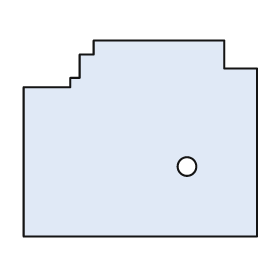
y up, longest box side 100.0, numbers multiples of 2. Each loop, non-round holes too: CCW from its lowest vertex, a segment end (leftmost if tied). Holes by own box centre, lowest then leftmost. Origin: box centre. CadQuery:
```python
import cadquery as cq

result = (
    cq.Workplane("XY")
    .moveTo(-50.0, -42.0)
    .lineTo(50.0, -42.0)
    .lineTo(50.0, 30.0)
    .lineTo(36.0, 30.0)
    .lineTo(36.0, 42.0)
    .lineTo(-20.0, 42.0)
    .lineTo(-20.0, 36.0)
    .lineTo(-26.0, 36.0)
    .lineTo(-26.0, 26.0)
    .lineTo(-30.0, 26.0)
    .lineTo(-30.0, 22.0)
    .lineTo(-50.0, 22.0)
    .close()
    .moveTo(20.0, -12.0)
    .circle(4.0)
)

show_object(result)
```